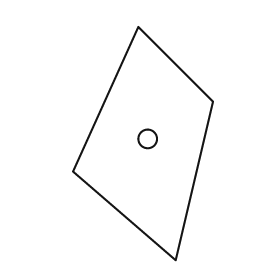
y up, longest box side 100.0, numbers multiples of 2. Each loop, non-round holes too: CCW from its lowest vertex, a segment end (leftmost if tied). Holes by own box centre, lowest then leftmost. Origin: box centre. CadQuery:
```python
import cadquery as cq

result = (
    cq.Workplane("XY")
    .moveTo(14.0, -50.0)
    .lineTo(30.0, 18.0)
    .lineTo(-2.0, 50.0)
    .lineTo(-30.0, -12.0)
    .close()
    .moveTo(2.0, 2.0)
    .circle(4.0)
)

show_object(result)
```